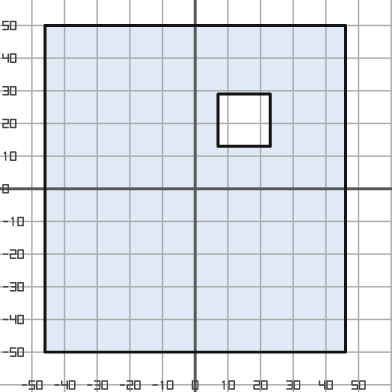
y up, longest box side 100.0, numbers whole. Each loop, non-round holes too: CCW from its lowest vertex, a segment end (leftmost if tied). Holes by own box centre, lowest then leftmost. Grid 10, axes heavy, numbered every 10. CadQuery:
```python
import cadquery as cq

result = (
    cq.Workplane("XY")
    .moveTo(-46.0, -50.0)
    .lineTo(46.0, -50.0)
    .lineTo(46.0, 50.0)
    .lineTo(-46.0, 50.0)
    .close()
    .moveTo(7.0, 13.0)
    .lineTo(23.0, 13.0)
    .lineTo(23.0, 29.0)
    .lineTo(7.0, 29.0)
    .close()
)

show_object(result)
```